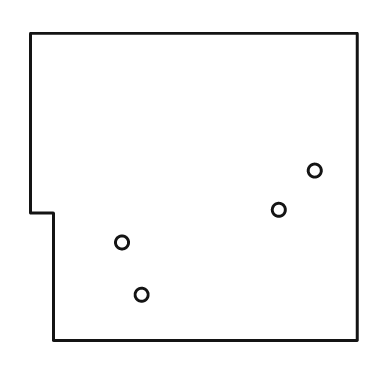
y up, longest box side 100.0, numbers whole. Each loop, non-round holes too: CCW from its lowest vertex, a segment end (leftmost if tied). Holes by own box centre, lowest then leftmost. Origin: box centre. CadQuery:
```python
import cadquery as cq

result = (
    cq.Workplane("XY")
    .moveTo(-43.0, -47.0)
    .lineTo(50.0, -47.0)
    .lineTo(50.0, 47.0)
    .lineTo(-50.0, 47.0)
    .lineTo(-50.0, -8.0)
    .lineTo(-43.0, -8.0)
    .close()
    .moveTo(-16.0, -33.0)
    .circle(2.0)
    .moveTo(-22.0, -17.0)
    .circle(2.0)
    .moveTo(26.0, -7.0)
    .circle(2.0)
    .moveTo(37.0, 5.0)
    .circle(2.0)
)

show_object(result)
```